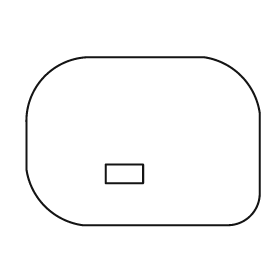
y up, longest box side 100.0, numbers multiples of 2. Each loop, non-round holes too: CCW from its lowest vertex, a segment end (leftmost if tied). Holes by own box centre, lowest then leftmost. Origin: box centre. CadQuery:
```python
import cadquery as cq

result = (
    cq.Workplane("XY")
    .moveTo(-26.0, -36.0)
    .lineTo(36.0, -36.0)
    .threePointArc((46.0, -32.0), (50.0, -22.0))
    .lineTo(50.0, 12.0)
    .threePointArc((42.0, 28.0), (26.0, 36.0))
    .lineTo(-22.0, 36.0)
    .threePointArc((-42.0, 28.0), (-50.0, 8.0))
    .lineTo(-50.0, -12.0)
    .threePointArc((-42.0, -28.0), (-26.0, -36.0))
    .close()
    .moveTo(-16.0, -18.0)
    .lineTo(0.0, -18.0)
    .lineTo(0.0, -10.0)
    .lineTo(-16.0, -10.0)
    .close()
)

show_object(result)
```